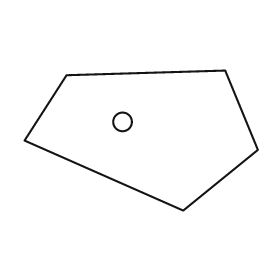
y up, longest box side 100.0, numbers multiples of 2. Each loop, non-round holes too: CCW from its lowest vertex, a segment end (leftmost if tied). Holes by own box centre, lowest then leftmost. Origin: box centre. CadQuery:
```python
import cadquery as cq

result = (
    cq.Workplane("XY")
    .moveTo(18.0, -30.0)
    .lineTo(50.0, -4.0)
    .lineTo(36.0, 30.0)
    .lineTo(-32.0, 28.0)
    .lineTo(-50.0, 0.0)
    .close()
    .moveTo(-8.0, 8.0)
    .circle(4.0)
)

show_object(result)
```